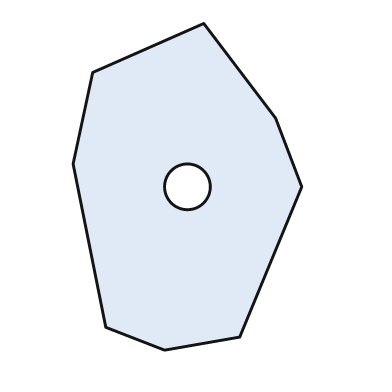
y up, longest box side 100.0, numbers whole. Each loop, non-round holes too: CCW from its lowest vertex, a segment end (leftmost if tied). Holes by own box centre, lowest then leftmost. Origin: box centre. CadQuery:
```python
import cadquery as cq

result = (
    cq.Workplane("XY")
    .moveTo(-7.0, -50.0)
    .lineTo(16.0, -46.0)
    .lineTo(35.0, 0.0)
    .lineTo(27.0, 21.0)
    .lineTo(5.0, 50.0)
    .lineTo(-29.0, 35.0)
    .lineTo(-35.0, 7.0)
    .lineTo(-25.0, -43.0)
    .close()
    .moveTo(0.0, 0.0)
    .circle(7.0)
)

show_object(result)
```